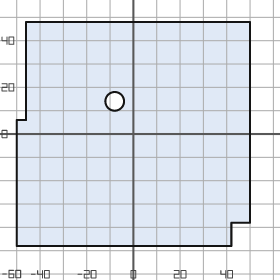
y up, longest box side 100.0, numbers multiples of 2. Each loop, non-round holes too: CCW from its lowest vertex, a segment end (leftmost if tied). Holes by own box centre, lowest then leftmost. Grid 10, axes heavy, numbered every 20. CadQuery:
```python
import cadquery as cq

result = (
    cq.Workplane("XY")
    .moveTo(-50.0, -48.0)
    .lineTo(42.0, -48.0)
    .lineTo(42.0, -38.0)
    .lineTo(50.0, -38.0)
    .lineTo(50.0, 48.0)
    .lineTo(-46.0, 48.0)
    .lineTo(-46.0, 6.0)
    .lineTo(-50.0, 6.0)
    .close()
    .moveTo(-8.0, 14.0)
    .circle(4.0)
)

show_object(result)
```